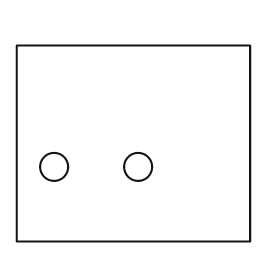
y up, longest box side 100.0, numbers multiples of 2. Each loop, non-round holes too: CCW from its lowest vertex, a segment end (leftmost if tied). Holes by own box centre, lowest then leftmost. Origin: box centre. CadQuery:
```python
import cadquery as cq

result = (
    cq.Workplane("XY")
    .moveTo(-50.0, -42.0)
    .lineTo(50.0, -42.0)
    .lineTo(50.0, 42.0)
    .lineTo(-50.0, 42.0)
    .close()
    .moveTo(-34.0, -10.0)
    .circle(6.0)
    .moveTo(2.0, -10.0)
    .circle(6.0)
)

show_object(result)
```